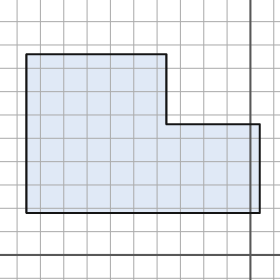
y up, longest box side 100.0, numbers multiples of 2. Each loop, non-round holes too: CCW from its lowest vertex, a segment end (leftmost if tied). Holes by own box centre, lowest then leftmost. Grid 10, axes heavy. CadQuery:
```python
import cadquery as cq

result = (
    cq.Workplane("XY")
    .moveTo(-96.0, 18.0)
    .lineTo(4.0, 18.0)
    .lineTo(4.0, 56.0)
    .lineTo(-36.0, 56.0)
    .lineTo(-36.0, 86.0)
    .lineTo(-96.0, 86.0)
    .close()
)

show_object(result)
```